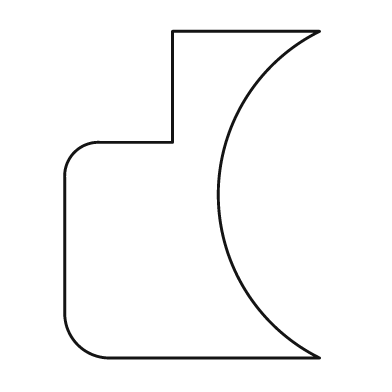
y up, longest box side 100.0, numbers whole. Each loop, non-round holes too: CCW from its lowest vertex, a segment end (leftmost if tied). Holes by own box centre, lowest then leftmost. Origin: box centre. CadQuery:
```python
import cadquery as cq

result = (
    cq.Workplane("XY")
    .moveTo(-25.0, -50.0)
    .lineTo(39.0, -50.0)
    .threePointArc((8.0, 0.0), (39.0, 50.0))
    .lineTo(-6.0, 50.0)
    .lineTo(-6.0, 16.0)
    .lineTo(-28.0, 16.0)
    .threePointArc((-36.0, 13.0), (-39.0, 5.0))
    .lineTo(-39.0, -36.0)
    .threePointArc((-35.0, -46.0), (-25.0, -50.0))
    .close()
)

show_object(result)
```